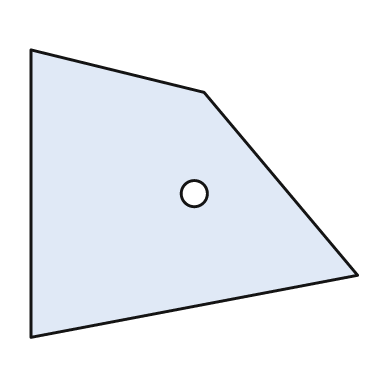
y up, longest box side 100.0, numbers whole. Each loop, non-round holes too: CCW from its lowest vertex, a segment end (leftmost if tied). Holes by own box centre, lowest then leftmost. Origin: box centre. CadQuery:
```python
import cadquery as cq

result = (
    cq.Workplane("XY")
    .moveTo(-50.0, -44.0)
    .lineTo(50.0, -25.0)
    .lineTo(3.0, 31.0)
    .lineTo(-50.0, 44.0)
    .close()
    .moveTo(0.0, 0.0)
    .circle(4.0)
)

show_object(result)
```